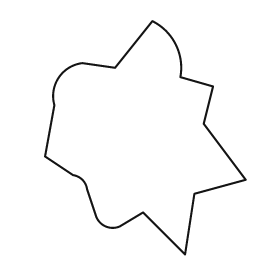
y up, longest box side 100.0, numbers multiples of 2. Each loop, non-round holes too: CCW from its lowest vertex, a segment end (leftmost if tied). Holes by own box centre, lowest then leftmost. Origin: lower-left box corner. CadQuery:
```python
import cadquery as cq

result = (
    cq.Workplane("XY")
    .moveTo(60.0, 0.0)
    .lineTo(64.0, 26.0)
    .lineTo(86.0, 32.0)
    .lineTo(68.0, 56.0)
    .lineTo(72.0, 72.0)
    .lineTo(58.0, 76.0)
    .threePointArc((56.0, 90.0), (46.0, 100.0))
    .lineTo(30.0, 80.0)
    .lineTo(16.0, 82.0)
    .threePointArc((6.0, 76.0), (4.0, 64.0))
    .lineTo(0.0, 42.0)
    .lineTo(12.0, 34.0)
    .threePointArc((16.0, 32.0), (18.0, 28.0))
    .lineTo(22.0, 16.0)
    .threePointArc((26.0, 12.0), (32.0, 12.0))
    .lineTo(42.0, 18.0)
    .close()
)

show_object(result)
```